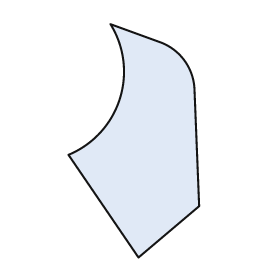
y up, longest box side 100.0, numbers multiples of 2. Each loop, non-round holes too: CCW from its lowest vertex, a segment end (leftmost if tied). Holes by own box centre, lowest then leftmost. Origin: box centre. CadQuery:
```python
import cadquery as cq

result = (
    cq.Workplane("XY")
    .moveTo(2.0, -50.0)
    .lineTo(28.0, -28.0)
    .lineTo(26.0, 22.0)
    .threePointArc((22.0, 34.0), (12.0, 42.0))
    .lineTo(-10.0, 50.0)
    .threePointArc((-6.0, 18.0), (-28.0, -6.0))
    .close()
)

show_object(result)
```